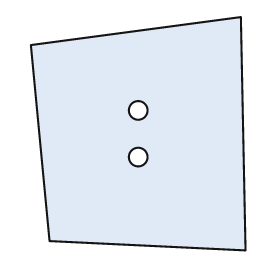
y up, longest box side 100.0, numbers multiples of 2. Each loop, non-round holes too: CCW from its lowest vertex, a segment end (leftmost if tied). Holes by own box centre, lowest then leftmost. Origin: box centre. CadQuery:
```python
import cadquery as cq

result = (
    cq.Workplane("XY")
    .moveTo(46.0, -50.0)
    .lineTo(44.0, 50.0)
    .lineTo(-46.0, 38.0)
    .lineTo(-38.0, -46.0)
    .close()
    .moveTo(0.0, -10.0)
    .circle(4.0)
    .moveTo(0.0, 10.0)
    .circle(4.0)
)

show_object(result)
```